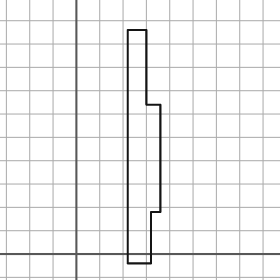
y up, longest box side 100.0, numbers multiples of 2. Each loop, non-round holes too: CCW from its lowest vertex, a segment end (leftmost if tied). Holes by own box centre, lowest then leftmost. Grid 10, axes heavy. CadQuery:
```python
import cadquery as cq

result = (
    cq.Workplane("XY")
    .moveTo(22.0, -4.0)
    .lineTo(32.0, -4.0)
    .lineTo(32.0, 18.0)
    .lineTo(36.0, 18.0)
    .lineTo(36.0, 64.0)
    .lineTo(30.0, 64.0)
    .lineTo(30.0, 96.0)
    .lineTo(22.0, 96.0)
    .close()
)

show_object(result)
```